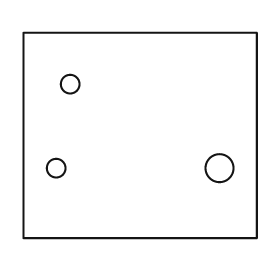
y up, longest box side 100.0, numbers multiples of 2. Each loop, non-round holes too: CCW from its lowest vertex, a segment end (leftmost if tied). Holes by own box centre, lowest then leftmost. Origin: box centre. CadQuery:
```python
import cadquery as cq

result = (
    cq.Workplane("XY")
    .moveTo(-50.0, -44.0)
    .lineTo(50.0, -44.0)
    .lineTo(50.0, 44.0)
    .lineTo(-50.0, 44.0)
    .close()
    .moveTo(-36.0, -14.0)
    .circle(4.0)
    .moveTo(34.0, -14.0)
    .circle(6.0)
    .moveTo(-30.0, 22.0)
    .circle(4.0)
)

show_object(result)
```